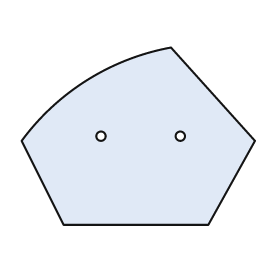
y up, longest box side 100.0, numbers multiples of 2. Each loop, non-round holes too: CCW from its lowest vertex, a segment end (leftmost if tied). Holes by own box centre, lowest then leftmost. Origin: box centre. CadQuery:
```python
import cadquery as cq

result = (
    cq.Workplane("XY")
    .moveTo(-32.0, -38.0)
    .lineTo(30.0, -38.0)
    .lineTo(50.0, -2.0)
    .lineTo(14.0, 38.0)
    .threePointArc((-22.0, 24.0), (-50.0, -2.0))
    .close()
    .moveTo(-16.0, 0.0)
    .circle(2.0)
    .moveTo(18.0, 0.0)
    .circle(2.0)
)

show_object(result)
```